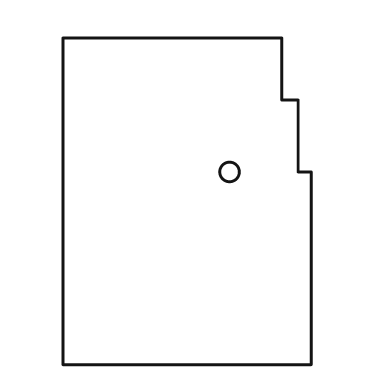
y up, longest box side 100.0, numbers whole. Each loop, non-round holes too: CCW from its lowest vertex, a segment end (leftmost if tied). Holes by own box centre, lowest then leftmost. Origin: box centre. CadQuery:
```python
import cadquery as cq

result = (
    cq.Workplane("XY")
    .moveTo(-38.0, -50.0)
    .lineTo(38.0, -50.0)
    .lineTo(38.0, 9.0)
    .lineTo(34.0, 9.0)
    .lineTo(34.0, 31.0)
    .lineTo(29.0, 31.0)
    .lineTo(29.0, 50.0)
    .lineTo(-38.0, 50.0)
    .close()
    .moveTo(13.0, 9.0)
    .circle(3.0)
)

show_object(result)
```